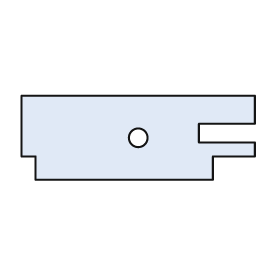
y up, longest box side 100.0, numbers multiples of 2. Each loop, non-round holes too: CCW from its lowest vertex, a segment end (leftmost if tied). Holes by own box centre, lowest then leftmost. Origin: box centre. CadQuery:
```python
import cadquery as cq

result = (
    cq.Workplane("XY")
    .moveTo(-44.0, -18.0)
    .lineTo(32.0, -18.0)
    .lineTo(32.0, -8.0)
    .lineTo(50.0, -8.0)
    .lineTo(50.0, -2.0)
    .lineTo(26.0, -2.0)
    .lineTo(26.0, 6.0)
    .lineTo(50.0, 6.0)
    .lineTo(50.0, 18.0)
    .lineTo(-50.0, 18.0)
    .lineTo(-50.0, -8.0)
    .lineTo(-44.0, -8.0)
    .close()
    .moveTo(0.0, 0.0)
    .circle(4.0)
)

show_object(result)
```